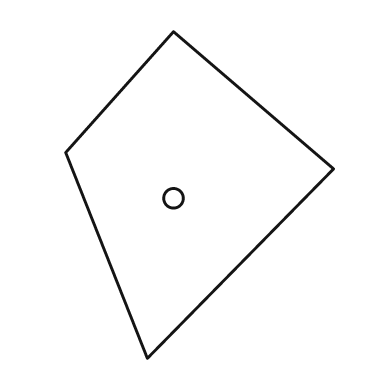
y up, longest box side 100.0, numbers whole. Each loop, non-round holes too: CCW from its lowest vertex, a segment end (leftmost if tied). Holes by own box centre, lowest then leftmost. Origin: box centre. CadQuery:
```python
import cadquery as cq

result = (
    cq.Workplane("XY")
    .moveTo(-16.0, -50.0)
    .lineTo(41.0, 8.0)
    .lineTo(-8.0, 50.0)
    .lineTo(-41.0, 13.0)
    .close()
    .moveTo(-8.0, -1.0)
    .circle(3.0)
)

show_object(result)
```